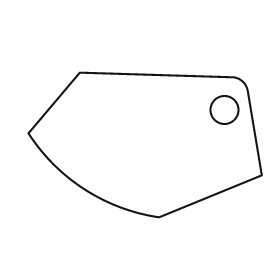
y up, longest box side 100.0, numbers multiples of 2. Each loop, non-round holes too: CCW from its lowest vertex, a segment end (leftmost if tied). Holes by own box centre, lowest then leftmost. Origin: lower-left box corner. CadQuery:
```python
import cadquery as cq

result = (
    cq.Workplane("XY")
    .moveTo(56.0, 0.0)
    .lineTo(100.0, 18.0)
    .lineTo(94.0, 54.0)
    .threePointArc((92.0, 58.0), (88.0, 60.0))
    .lineTo(22.0, 62.0)
    .lineTo(0.0, 36.0)
    .threePointArc((24.0, 12.0), (56.0, 0.0))
    .close()
    .moveTo(84.0, 46.0)
    .circle(6.0)
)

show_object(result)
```